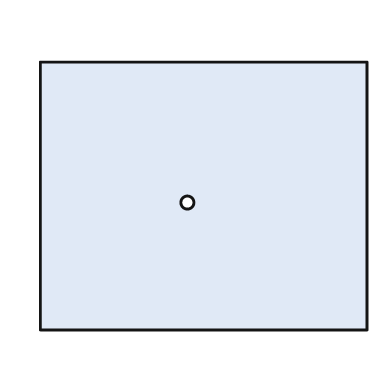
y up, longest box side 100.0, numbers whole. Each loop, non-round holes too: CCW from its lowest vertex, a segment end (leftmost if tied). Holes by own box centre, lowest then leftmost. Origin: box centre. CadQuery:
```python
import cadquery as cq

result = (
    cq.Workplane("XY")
    .moveTo(-50.0, -41.0)
    .lineTo(50.0, -41.0)
    .lineTo(50.0, 41.0)
    .lineTo(-50.0, 41.0)
    .close()
    .moveTo(-5.0, -2.0)
    .circle(2.0)
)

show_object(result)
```